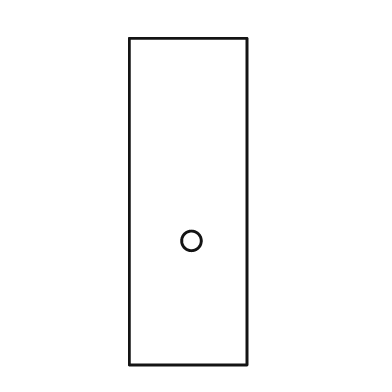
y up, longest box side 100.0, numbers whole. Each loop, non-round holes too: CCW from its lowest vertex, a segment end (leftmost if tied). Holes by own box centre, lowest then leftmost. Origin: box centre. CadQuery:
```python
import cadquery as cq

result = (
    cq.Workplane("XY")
    .moveTo(-18.0, -50.0)
    .lineTo(18.0, -50.0)
    .lineTo(18.0, 50.0)
    .lineTo(-18.0, 50.0)
    .close()
    .moveTo(1.0, -12.0)
    .circle(3.0)
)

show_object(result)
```